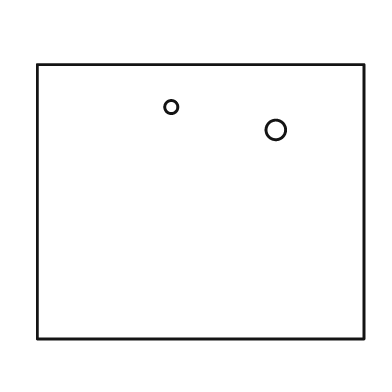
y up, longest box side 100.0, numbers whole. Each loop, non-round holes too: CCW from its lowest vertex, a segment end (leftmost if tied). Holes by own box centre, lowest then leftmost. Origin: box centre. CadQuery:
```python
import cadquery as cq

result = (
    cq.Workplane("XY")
    .moveTo(-50.0, -42.0)
    .lineTo(50.0, -42.0)
    .lineTo(50.0, 42.0)
    .lineTo(-50.0, 42.0)
    .close()
    .moveTo(23.0, 22.0)
    .circle(3.0)
    .moveTo(-9.0, 29.0)
    .circle(2.0)
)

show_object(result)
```